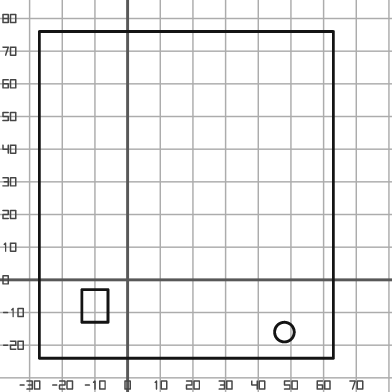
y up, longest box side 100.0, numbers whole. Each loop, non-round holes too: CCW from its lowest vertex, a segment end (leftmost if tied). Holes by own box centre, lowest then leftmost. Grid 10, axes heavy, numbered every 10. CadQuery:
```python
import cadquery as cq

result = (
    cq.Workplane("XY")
    .moveTo(-27.0, -24.0)
    .lineTo(63.0, -24.0)
    .lineTo(63.0, 76.0)
    .lineTo(-27.0, 76.0)
    .close()
    .moveTo(48.0, -16.0)
    .circle(3.0)
    .moveTo(-14.0, -13.0)
    .lineTo(-6.0, -13.0)
    .lineTo(-6.0, -3.0)
    .lineTo(-14.0, -3.0)
    .close()
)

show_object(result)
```